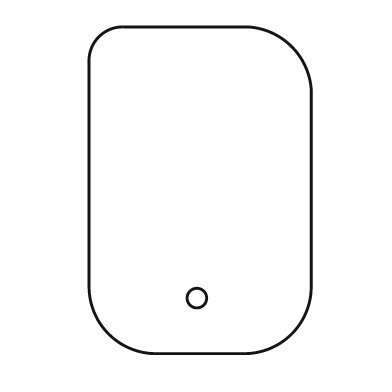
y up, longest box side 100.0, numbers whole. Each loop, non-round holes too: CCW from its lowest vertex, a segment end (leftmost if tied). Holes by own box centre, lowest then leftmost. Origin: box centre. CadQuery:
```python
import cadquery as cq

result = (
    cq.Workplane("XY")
    .moveTo(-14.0, -50.0)
    .lineTo(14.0, -50.0)
    .threePointArc((28.0, -44.0), (34.0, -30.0))
    .lineTo(34.0, 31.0)
    .threePointArc((28.0, 44.0), (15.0, 50.0))
    .lineTo(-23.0, 50.0)
    .threePointArc((-31.0, 47.0), (-34.0, 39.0))
    .lineTo(-34.0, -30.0)
    .threePointArc((-28.0, -44.0), (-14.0, -50.0))
    .close()
    .moveTo(-1.0, -33.0)
    .circle(3.0)
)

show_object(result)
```